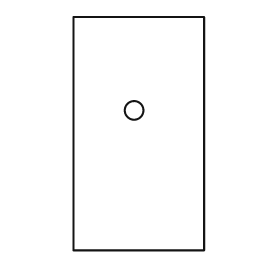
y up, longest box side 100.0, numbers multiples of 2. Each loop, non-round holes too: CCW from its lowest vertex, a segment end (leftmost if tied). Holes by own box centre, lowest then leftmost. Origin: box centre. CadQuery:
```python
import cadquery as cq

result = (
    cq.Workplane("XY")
    .moveTo(-28.0, -50.0)
    .lineTo(28.0, -50.0)
    .lineTo(28.0, 50.0)
    .lineTo(-28.0, 50.0)
    .close()
    .moveTo(-2.0, 10.0)
    .circle(4.0)
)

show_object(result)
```